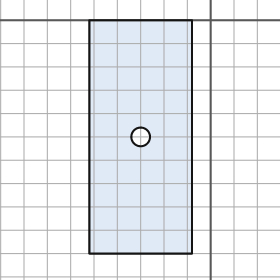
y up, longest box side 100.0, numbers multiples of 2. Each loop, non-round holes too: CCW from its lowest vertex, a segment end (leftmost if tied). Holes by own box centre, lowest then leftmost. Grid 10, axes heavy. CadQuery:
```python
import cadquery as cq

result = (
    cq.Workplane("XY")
    .moveTo(-52.0, -100.0)
    .lineTo(-8.0, -100.0)
    .lineTo(-8.0, 0.0)
    .lineTo(-52.0, 0.0)
    .close()
    .moveTo(-30.0, -50.0)
    .circle(4.0)
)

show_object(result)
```